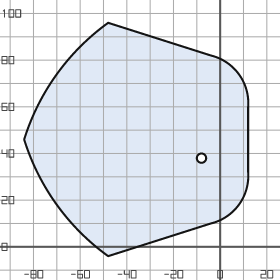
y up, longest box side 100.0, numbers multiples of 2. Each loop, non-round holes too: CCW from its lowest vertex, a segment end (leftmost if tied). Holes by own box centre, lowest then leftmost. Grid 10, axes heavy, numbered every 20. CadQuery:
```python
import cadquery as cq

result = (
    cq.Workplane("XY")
    .moveTo(-48.0, -4.0)
    .lineTo(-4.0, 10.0)
    .threePointArc((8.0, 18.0), (12.0, 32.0))
    .lineTo(12.0, 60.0)
    .threePointArc((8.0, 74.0), (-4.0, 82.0))
    .lineTo(-48.0, 96.0)
    .threePointArc((-70.0, 74.0), (-84.0, 46.0))
    .threePointArc((-70.0, 18.0), (-48.0, -4.0))
    .close()
    .moveTo(-8.0, 38.0)
    .circle(2.0)
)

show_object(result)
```